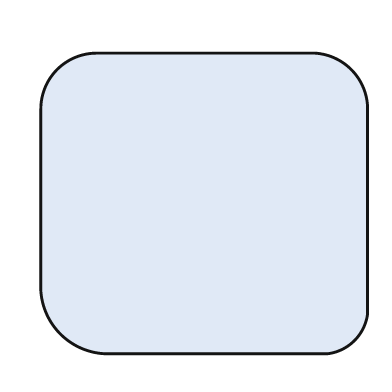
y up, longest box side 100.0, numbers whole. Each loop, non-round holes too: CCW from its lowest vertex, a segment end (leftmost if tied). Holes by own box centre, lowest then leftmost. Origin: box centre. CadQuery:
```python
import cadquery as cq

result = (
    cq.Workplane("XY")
    .moveTo(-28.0, -46.0)
    .lineTo(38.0, -46.0)
    .threePointArc((46.0, -42.0), (50.0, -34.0))
    .lineTo(50.0, 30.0)
    .threePointArc((45.0, 41.0), (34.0, 46.0))
    .lineTo(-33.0, 46.0)
    .threePointArc((-45.0, 41.0), (-50.0, 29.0))
    .lineTo(-50.0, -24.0)
    .threePointArc((-44.0, -40.0), (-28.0, -46.0))
    .close()
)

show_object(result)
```